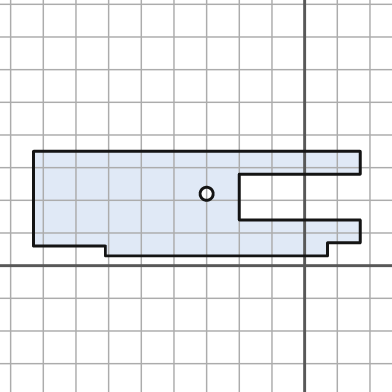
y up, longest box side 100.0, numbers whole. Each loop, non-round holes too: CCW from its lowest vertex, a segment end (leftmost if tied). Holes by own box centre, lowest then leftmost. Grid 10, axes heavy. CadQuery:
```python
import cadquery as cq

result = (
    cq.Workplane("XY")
    .moveTo(-61.0, 3.0)
    .lineTo(7.0, 3.0)
    .lineTo(7.0, 7.0)
    .lineTo(17.0, 7.0)
    .lineTo(17.0, 14.0)
    .lineTo(-20.0, 14.0)
    .lineTo(-20.0, 28.0)
    .lineTo(17.0, 28.0)
    .lineTo(17.0, 35.0)
    .lineTo(-83.0, 35.0)
    .lineTo(-83.0, 6.0)
    .lineTo(-61.0, 6.0)
    .close()
    .moveTo(-30.0, 22.0)
    .circle(2.0)
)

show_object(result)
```